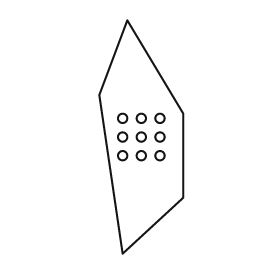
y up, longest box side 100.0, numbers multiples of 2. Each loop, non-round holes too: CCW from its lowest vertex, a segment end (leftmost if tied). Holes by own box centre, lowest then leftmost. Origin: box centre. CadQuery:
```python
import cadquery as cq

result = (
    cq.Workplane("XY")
    .moveTo(-8.0, -50.0)
    .lineTo(18.0, -26.0)
    .lineTo(18.0, 10.0)
    .lineTo(-6.0, 50.0)
    .lineTo(-18.0, 18.0)
    .close()
    .moveTo(-8.0, -8.0)
    .circle(2.0)
    .moveTo(0.0, -8.0)
    .circle(2.0)
    .moveTo(8.0, -8.0)
    .circle(2.0)
    .moveTo(-8.0, 0.0)
    .circle(2.0)
    .moveTo(0.0, 0.0)
    .circle(2.0)
    .moveTo(8.0, 0.0)
    .circle(2.0)
    .moveTo(-8.0, 8.0)
    .circle(2.0)
    .moveTo(0.0, 8.0)
    .circle(2.0)
    .moveTo(8.0, 8.0)
    .circle(2.0)
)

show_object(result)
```